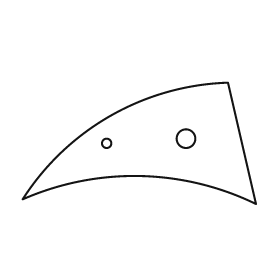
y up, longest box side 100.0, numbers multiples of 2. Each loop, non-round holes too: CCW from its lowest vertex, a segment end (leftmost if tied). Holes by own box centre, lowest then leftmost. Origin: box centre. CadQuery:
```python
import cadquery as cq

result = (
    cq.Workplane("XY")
    .moveTo(50.0, -26.0)
    .lineTo(38.0, 26.0)
    .threePointArc((-12.0, 12.0), (-50.0, -24.0))
    .threePointArc((0.0, -14.0), (50.0, -26.0))
    .close()
    .moveTo(-14.0, 0.0)
    .circle(2.0)
    .moveTo(20.0, 2.0)
    .circle(4.0)
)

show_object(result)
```